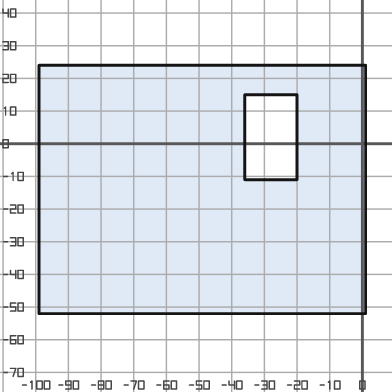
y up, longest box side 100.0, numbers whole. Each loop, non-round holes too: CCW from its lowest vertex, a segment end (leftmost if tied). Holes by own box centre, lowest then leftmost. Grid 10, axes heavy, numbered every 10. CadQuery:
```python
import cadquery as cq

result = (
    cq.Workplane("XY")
    .moveTo(-99.0, -52.0)
    .lineTo(1.0, -52.0)
    .lineTo(1.0, 24.0)
    .lineTo(-99.0, 24.0)
    .close()
    .moveTo(-36.0, -11.0)
    .lineTo(-20.0, -11.0)
    .lineTo(-20.0, 15.0)
    .lineTo(-36.0, 15.0)
    .close()
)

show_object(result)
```